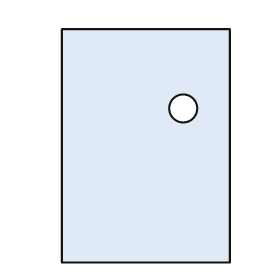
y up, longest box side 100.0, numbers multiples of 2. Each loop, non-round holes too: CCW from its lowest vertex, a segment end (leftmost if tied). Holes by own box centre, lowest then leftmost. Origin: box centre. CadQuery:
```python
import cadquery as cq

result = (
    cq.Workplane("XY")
    .moveTo(-36.0, -50.0)
    .lineTo(36.0, -50.0)
    .lineTo(36.0, 50.0)
    .lineTo(-36.0, 50.0)
    .close()
    .moveTo(16.0, 16.0)
    .circle(6.0)
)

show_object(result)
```